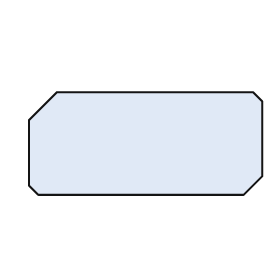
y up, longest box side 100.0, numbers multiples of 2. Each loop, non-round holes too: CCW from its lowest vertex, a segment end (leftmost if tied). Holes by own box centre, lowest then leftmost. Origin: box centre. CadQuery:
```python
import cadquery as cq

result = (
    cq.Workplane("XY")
    .moveTo(-46.0, -22.0)
    .lineTo(42.0, -22.0)
    .lineTo(50.0, -14.0)
    .lineTo(50.0, 18.0)
    .lineTo(46.0, 22.0)
    .lineTo(-38.0, 22.0)
    .lineTo(-50.0, 10.0)
    .lineTo(-50.0, -18.0)
    .close()
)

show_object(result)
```